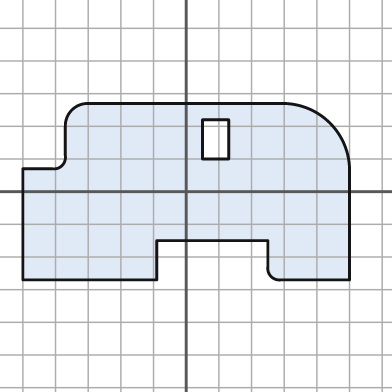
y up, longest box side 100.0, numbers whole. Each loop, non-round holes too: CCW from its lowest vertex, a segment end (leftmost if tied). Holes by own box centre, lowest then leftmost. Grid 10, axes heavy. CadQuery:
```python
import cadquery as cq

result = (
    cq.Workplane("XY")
    .moveTo(-50.0, -27.0)
    .lineTo(-9.0, -27.0)
    .lineTo(-9.0, -15.0)
    .lineTo(25.0, -15.0)
    .lineTo(25.0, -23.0)
    .threePointArc((26.0, -26.0), (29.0, -27.0))
    .lineTo(50.0, -27.0)
    .lineTo(50.0, 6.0)
    .threePointArc((44.0, 21.0), (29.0, 27.0))
    .lineTo(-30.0, 27.0)
    .threePointArc((-35.0, 25.0), (-37.0, 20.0))
    .lineTo(-37.0, 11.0)
    .threePointArc((-38.0, 8.0), (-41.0, 7.0))
    .lineTo(-50.0, 7.0)
    .close()
    .moveTo(5.0, 10.0)
    .lineTo(13.0, 10.0)
    .lineTo(13.0, 22.0)
    .lineTo(5.0, 22.0)
    .close()
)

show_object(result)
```